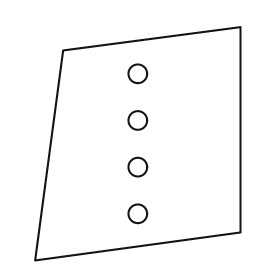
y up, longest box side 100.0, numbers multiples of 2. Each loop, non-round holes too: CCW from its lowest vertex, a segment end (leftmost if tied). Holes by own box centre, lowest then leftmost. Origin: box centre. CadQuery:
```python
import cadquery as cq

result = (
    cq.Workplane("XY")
    .moveTo(-44.0, -50.0)
    .lineTo(44.0, -38.0)
    .lineTo(44.0, 50.0)
    .lineTo(-32.0, 40.0)
    .close()
    .moveTo(0.0, -30.0)
    .circle(4.0)
    .moveTo(0.0, -10.0)
    .circle(4.0)
    .moveTo(0.0, 10.0)
    .circle(4.0)
    .moveTo(0.0, 30.0)
    .circle(4.0)
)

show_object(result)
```